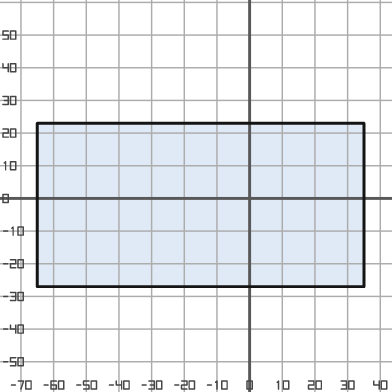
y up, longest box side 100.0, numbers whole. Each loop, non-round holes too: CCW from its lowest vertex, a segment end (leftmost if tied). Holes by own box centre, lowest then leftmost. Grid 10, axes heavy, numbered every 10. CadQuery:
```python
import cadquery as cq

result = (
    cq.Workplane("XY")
    .moveTo(-65.0, -27.0)
    .lineTo(35.0, -27.0)
    .lineTo(35.0, 23.0)
    .lineTo(-65.0, 23.0)
    .close()
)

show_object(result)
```